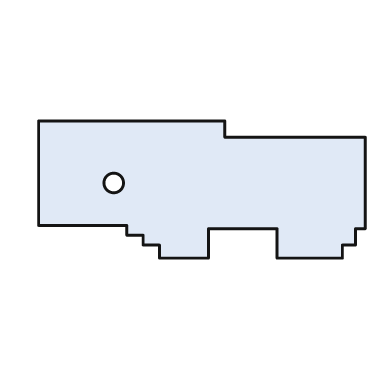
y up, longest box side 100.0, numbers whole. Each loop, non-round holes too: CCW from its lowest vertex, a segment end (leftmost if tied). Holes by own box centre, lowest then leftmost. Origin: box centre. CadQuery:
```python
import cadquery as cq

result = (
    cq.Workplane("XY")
    .moveTo(-13.0, -21.0)
    .lineTo(2.0, -21.0)
    .lineTo(2.0, -12.0)
    .lineTo(23.0, -12.0)
    .lineTo(23.0, -21.0)
    .lineTo(43.0, -21.0)
    .lineTo(43.0, -17.0)
    .lineTo(47.0, -17.0)
    .lineTo(47.0, -12.0)
    .lineTo(50.0, -12.0)
    .lineTo(50.0, 16.0)
    .lineTo(7.0, 16.0)
    .lineTo(7.0, 21.0)
    .lineTo(-50.0, 21.0)
    .lineTo(-50.0, -11.0)
    .lineTo(-23.0, -11.0)
    .lineTo(-23.0, -14.0)
    .lineTo(-18.0, -14.0)
    .lineTo(-18.0, -17.0)
    .lineTo(-13.0, -17.0)
    .close()
    .moveTo(-27.0, 2.0)
    .circle(3.0)
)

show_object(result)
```